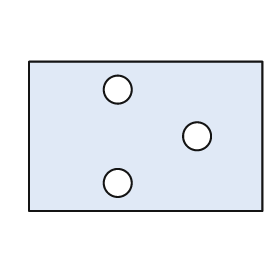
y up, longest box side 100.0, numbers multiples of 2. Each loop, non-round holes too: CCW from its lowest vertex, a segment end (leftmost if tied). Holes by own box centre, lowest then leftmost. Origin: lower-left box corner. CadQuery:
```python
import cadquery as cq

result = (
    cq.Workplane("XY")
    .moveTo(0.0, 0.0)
    .lineTo(100.0, 0.0)
    .lineTo(100.0, 64.0)
    .lineTo(0.0, 64.0)
    .close()
    .moveTo(38.0, 12.0)
    .circle(6.0)
    .moveTo(72.0, 32.0)
    .circle(6.0)
    .moveTo(38.0, 52.0)
    .circle(6.0)
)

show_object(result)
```